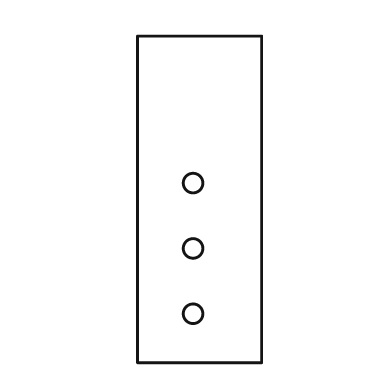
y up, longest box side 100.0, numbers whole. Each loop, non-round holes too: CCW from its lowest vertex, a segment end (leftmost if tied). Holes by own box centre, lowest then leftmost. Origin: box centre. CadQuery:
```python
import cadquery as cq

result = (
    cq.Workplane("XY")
    .moveTo(-19.0, -50.0)
    .lineTo(19.0, -50.0)
    .lineTo(19.0, 50.0)
    .lineTo(-19.0, 50.0)
    .close()
    .moveTo(-2.0, -35.0)
    .circle(3.0)
    .moveTo(-2.0, -15.0)
    .circle(3.0)
    .moveTo(-2.0, 5.0)
    .circle(3.0)
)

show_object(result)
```